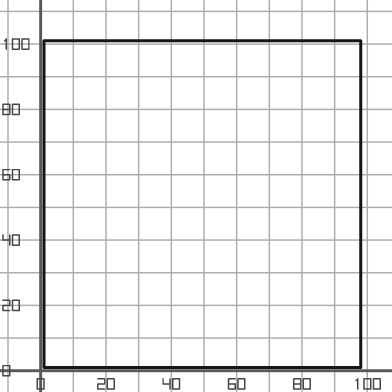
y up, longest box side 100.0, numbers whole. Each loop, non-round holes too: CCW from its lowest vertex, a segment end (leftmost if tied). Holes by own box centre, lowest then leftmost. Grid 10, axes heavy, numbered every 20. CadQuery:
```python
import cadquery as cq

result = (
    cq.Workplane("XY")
    .moveTo(1.0, 1.0)
    .lineTo(98.0, 1.0)
    .lineTo(98.0, 101.0)
    .lineTo(1.0, 101.0)
    .close()
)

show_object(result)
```